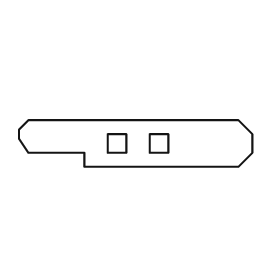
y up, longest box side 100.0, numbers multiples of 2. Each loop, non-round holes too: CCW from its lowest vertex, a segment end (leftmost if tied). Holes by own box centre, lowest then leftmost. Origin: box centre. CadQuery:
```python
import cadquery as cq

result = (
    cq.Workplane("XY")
    .moveTo(-22.0, -10.0)
    .lineTo(44.0, -10.0)
    .lineTo(50.0, -4.0)
    .lineTo(50.0, 4.0)
    .lineTo(44.0, 10.0)
    .lineTo(-46.0, 10.0)
    .lineTo(-50.0, 6.0)
    .lineTo(-50.0, 2.0)
    .lineTo(-46.0, -4.0)
    .lineTo(-22.0, -4.0)
    .close()
    .moveTo(-12.0, -4.0)
    .lineTo(-4.0, -4.0)
    .lineTo(-4.0, 4.0)
    .lineTo(-12.0, 4.0)
    .close()
    .moveTo(6.0, -4.0)
    .lineTo(14.0, -4.0)
    .lineTo(14.0, 4.0)
    .lineTo(6.0, 4.0)
    .close()
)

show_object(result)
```